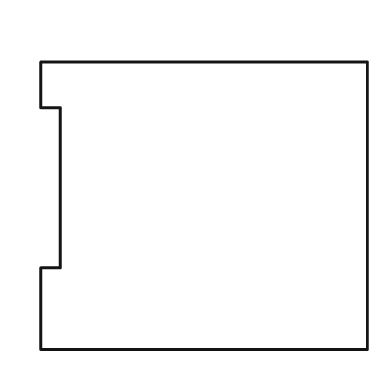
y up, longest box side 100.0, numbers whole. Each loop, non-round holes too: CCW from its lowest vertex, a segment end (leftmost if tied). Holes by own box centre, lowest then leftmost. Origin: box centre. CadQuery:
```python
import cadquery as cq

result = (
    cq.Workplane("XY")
    .moveTo(-50.0, -44.0)
    .lineTo(50.0, -44.0)
    .lineTo(50.0, 44.0)
    .lineTo(-50.0, 44.0)
    .lineTo(-50.0, 30.0)
    .lineTo(-44.0, 30.0)
    .lineTo(-44.0, -19.0)
    .lineTo(-50.0, -19.0)
    .close()
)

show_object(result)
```